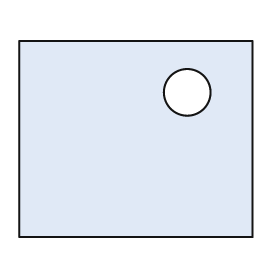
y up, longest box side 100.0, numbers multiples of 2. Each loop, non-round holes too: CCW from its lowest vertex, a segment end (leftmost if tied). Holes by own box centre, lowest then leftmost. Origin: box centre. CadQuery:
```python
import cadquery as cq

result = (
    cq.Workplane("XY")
    .moveTo(-50.0, -42.0)
    .lineTo(50.0, -42.0)
    .lineTo(50.0, 42.0)
    .lineTo(-50.0, 42.0)
    .close()
    .moveTo(22.0, 20.0)
    .circle(10.0)
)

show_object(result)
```